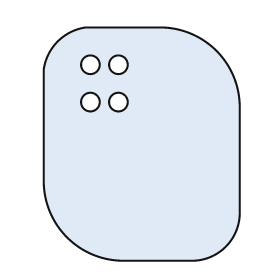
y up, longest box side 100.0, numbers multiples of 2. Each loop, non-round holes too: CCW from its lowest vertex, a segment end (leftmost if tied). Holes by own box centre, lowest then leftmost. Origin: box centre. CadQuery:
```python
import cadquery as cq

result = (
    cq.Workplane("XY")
    .moveTo(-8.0, -50.0)
    .lineTo(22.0, -50.0)
    .threePointArc((36.0, -44.0), (42.0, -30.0))
    .lineTo(42.0, 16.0)
    .threePointArc((32.0, 40.0), (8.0, 50.0))
    .lineTo(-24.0, 50.0)
    .threePointArc((-36.0, 44.0), (-42.0, 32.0))
    .lineTo(-42.0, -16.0)
    .threePointArc((-32.0, -40.0), (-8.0, -50.0))
    .close()
    .moveTo(-22.0, 18.0)
    .circle(4.0)
    .moveTo(-10.0, 18.0)
    .circle(4.0)
    .moveTo(-22.0, 34.0)
    .circle(4.0)
    .moveTo(-10.0, 34.0)
    .circle(4.0)
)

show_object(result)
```